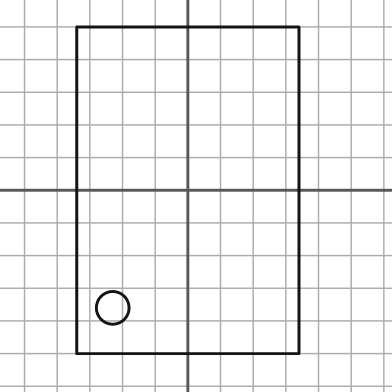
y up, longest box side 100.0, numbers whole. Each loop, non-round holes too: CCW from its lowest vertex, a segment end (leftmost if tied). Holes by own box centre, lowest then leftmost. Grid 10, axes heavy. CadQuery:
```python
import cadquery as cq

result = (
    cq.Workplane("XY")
    .moveTo(-34.0, -50.0)
    .lineTo(34.0, -50.0)
    .lineTo(34.0, 50.0)
    .lineTo(-34.0, 50.0)
    .close()
    .moveTo(-23.0, -36.0)
    .circle(5.0)
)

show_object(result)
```